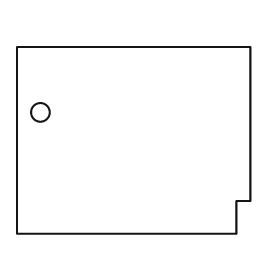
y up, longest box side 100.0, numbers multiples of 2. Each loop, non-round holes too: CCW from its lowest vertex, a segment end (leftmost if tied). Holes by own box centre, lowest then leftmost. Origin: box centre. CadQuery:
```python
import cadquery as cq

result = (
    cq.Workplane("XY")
    .moveTo(-50.0, -40.0)
    .lineTo(44.0, -40.0)
    .lineTo(44.0, -26.0)
    .lineTo(50.0, -26.0)
    .lineTo(50.0, 40.0)
    .lineTo(-50.0, 40.0)
    .close()
    .moveTo(-40.0, 12.0)
    .circle(4.0)
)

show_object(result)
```